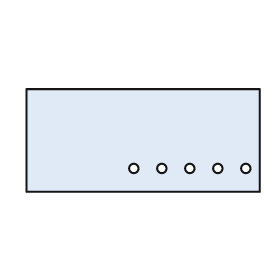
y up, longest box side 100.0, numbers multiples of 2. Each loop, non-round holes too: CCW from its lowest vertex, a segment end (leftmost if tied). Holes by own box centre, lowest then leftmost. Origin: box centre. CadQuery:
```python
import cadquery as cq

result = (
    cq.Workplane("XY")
    .moveTo(-50.0, -22.0)
    .lineTo(50.0, -22.0)
    .lineTo(50.0, 22.0)
    .lineTo(-50.0, 22.0)
    .close()
    .moveTo(-4.0, -12.0)
    .circle(2.0)
    .moveTo(8.0, -12.0)
    .circle(2.0)
    .moveTo(20.0, -12.0)
    .circle(2.0)
    .moveTo(32.0, -12.0)
    .circle(2.0)
    .moveTo(44.0, -12.0)
    .circle(2.0)
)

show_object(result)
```